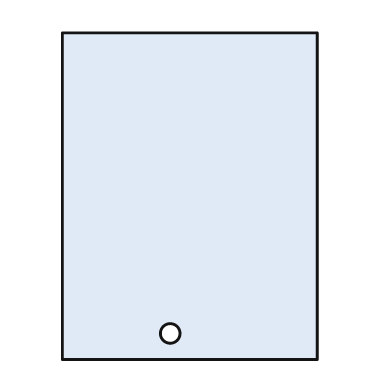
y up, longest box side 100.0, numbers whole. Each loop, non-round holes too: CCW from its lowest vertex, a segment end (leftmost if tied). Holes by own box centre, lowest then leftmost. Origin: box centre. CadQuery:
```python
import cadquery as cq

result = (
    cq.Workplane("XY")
    .moveTo(-39.0, -50.0)
    .lineTo(39.0, -50.0)
    .lineTo(39.0, 50.0)
    .lineTo(-39.0, 50.0)
    .close()
    .moveTo(-6.0, -42.0)
    .circle(3.0)
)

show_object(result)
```